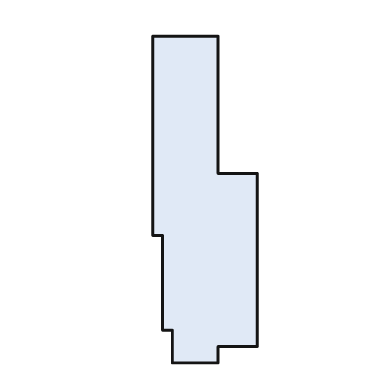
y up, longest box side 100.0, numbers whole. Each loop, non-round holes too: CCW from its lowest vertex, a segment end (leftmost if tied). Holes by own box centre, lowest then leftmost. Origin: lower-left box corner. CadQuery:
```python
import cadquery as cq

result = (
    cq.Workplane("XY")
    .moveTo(6.0, 0.0)
    .lineTo(20.0, 0.0)
    .lineTo(20.0, 5.0)
    .lineTo(32.0, 5.0)
    .lineTo(32.0, 58.0)
    .lineTo(20.0, 58.0)
    .lineTo(20.0, 100.0)
    .lineTo(0.0, 100.0)
    .lineTo(0.0, 39.0)
    .lineTo(3.0, 39.0)
    .lineTo(3.0, 10.0)
    .lineTo(6.0, 10.0)
    .close()
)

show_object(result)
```